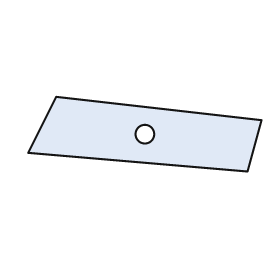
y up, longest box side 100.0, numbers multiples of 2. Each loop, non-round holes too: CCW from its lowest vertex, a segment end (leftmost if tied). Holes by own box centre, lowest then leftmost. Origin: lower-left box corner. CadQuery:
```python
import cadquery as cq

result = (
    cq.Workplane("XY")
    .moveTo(94.0, 0.0)
    .lineTo(100.0, 22.0)
    .lineTo(12.0, 32.0)
    .lineTo(0.0, 8.0)
    .close()
    .moveTo(50.0, 16.0)
    .circle(4.0)
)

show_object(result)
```